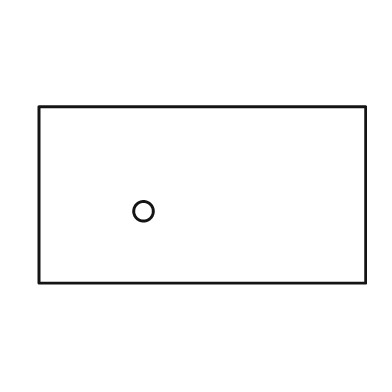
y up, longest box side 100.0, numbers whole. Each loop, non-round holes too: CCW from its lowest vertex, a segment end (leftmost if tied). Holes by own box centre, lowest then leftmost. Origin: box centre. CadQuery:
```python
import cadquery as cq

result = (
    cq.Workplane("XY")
    .moveTo(-50.0, -27.0)
    .lineTo(50.0, -27.0)
    .lineTo(50.0, 27.0)
    .lineTo(-50.0, 27.0)
    .close()
    .moveTo(-18.0, -5.0)
    .circle(3.0)
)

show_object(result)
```